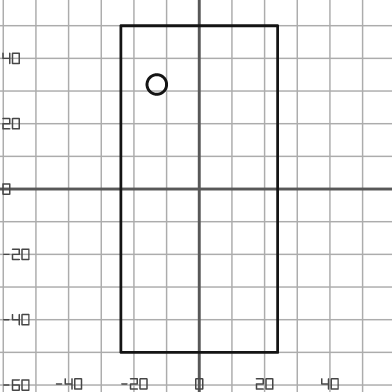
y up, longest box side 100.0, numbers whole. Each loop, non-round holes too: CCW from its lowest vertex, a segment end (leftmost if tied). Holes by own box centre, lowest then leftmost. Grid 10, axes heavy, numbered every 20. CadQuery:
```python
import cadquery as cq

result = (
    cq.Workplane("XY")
    .moveTo(-24.0, -50.0)
    .lineTo(24.0, -50.0)
    .lineTo(24.0, 50.0)
    .lineTo(-24.0, 50.0)
    .close()
    .moveTo(-13.0, 32.0)
    .circle(3.0)
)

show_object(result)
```